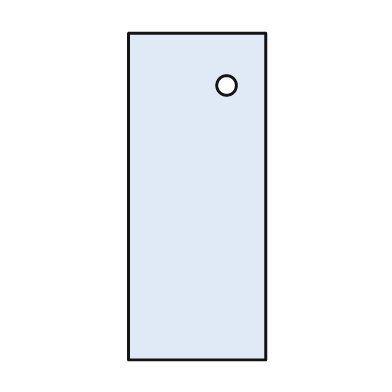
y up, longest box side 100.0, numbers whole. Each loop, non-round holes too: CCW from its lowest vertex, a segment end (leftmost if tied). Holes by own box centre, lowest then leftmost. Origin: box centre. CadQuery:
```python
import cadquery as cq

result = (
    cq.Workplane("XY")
    .moveTo(-21.0, -50.0)
    .lineTo(21.0, -50.0)
    .lineTo(21.0, 50.0)
    .lineTo(-21.0, 50.0)
    .close()
    .moveTo(9.0, 34.0)
    .circle(3.0)
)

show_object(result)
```